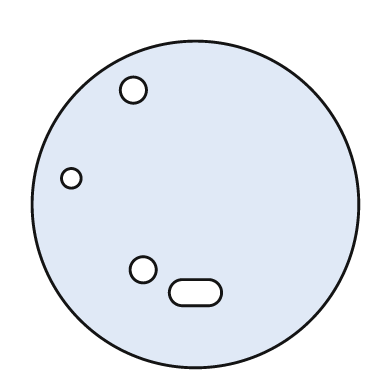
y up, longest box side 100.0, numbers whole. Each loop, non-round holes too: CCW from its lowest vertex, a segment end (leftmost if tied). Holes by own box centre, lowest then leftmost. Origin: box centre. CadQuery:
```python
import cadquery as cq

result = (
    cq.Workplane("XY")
    .moveTo(0.0, 0.0)
    .circle(50.0)
    .moveTo(-4.0, -31.0)
    .lineTo(4.0, -31.0)
    .threePointArc((8.0, -27.0), (4.0, -23.0))
    .lineTo(-4.0, -23.0)
    .threePointArc((-8.0, -27.0), (-4.0, -31.0))
    .close()
    .moveTo(-16.0, -20.0)
    .circle(4.0)
    .moveTo(-38.0, 8.0)
    .circle(3.0)
    .moveTo(-19.0, 35.0)
    .circle(4.0)
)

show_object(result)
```